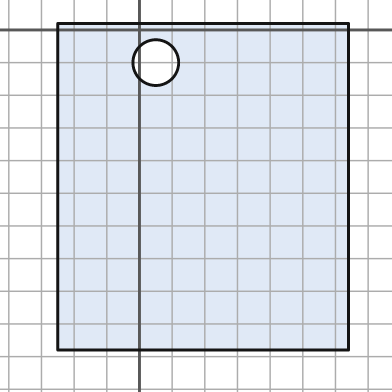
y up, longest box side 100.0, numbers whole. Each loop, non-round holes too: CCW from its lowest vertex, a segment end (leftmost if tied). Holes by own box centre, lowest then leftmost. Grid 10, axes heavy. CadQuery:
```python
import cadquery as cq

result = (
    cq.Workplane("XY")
    .moveTo(-25.0, -98.0)
    .lineTo(64.0, -98.0)
    .lineTo(64.0, 2.0)
    .lineTo(-25.0, 2.0)
    .close()
    .moveTo(5.0, -10.0)
    .circle(7.0)
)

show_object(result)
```